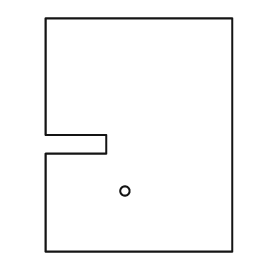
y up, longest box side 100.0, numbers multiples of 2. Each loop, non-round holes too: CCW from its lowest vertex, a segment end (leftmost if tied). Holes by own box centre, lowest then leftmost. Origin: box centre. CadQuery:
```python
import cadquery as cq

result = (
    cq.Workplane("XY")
    .moveTo(-40.0, -50.0)
    .lineTo(40.0, -50.0)
    .lineTo(40.0, 50.0)
    .lineTo(-40.0, 50.0)
    .lineTo(-40.0, 0.0)
    .lineTo(-14.0, 0.0)
    .lineTo(-14.0, -8.0)
    .lineTo(-40.0, -8.0)
    .close()
    .moveTo(-6.0, -24.0)
    .circle(2.0)
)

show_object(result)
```